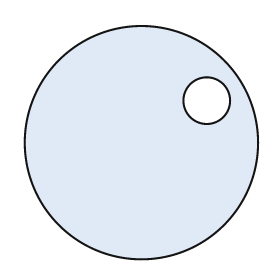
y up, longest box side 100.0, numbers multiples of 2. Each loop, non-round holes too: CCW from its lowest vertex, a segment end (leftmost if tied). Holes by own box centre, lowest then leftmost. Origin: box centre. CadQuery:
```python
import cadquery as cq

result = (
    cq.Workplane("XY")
    .moveTo(0.0, 0.0)
    .circle(50.0)
    .moveTo(28.0, 18.0)
    .circle(10.0)
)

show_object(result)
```